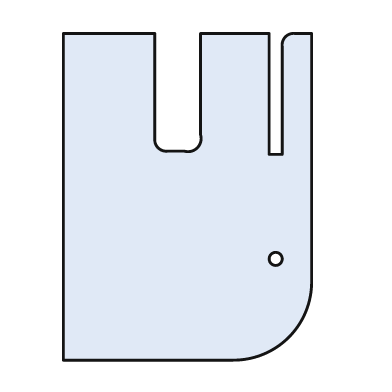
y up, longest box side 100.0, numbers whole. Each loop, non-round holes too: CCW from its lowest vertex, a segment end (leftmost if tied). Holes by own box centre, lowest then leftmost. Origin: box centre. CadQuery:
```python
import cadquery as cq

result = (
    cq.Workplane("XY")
    .moveTo(-38.0, -50.0)
    .lineTo(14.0, -50.0)
    .threePointArc((31.0, -43.0), (38.0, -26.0))
    .lineTo(38.0, 50.0)
    .lineTo(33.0, 50.0)
    .threePointArc((30.0, 49.0), (29.0, 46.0))
    .lineTo(29.0, 13.0)
    .lineTo(25.0, 13.0)
    .lineTo(25.0, 50.0)
    .lineTo(4.0, 50.0)
    .lineTo(4.0, 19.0)
    .threePointArc((3.0, 15.0), (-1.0, 14.0))
    .lineTo(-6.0, 14.0)
    .threePointArc((-9.0, 15.0), (-10.0, 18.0))
    .lineTo(-10.0, 50.0)
    .lineTo(-38.0, 50.0)
    .close()
    .moveTo(27.0, -19.0)
    .circle(2.0)
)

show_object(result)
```